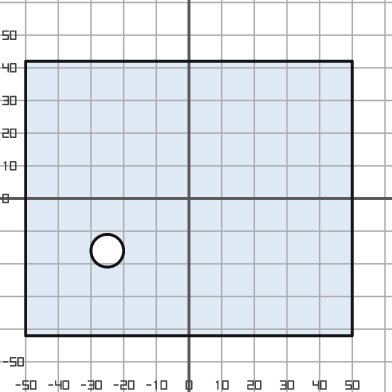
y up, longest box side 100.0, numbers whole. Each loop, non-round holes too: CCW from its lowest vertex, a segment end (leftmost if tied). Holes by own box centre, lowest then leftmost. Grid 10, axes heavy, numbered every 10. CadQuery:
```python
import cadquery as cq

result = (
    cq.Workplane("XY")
    .moveTo(-50.0, -42.0)
    .lineTo(50.0, -42.0)
    .lineTo(50.0, 42.0)
    .lineTo(-50.0, 42.0)
    .close()
    .moveTo(-25.0, -16.0)
    .circle(5.0)
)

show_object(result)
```